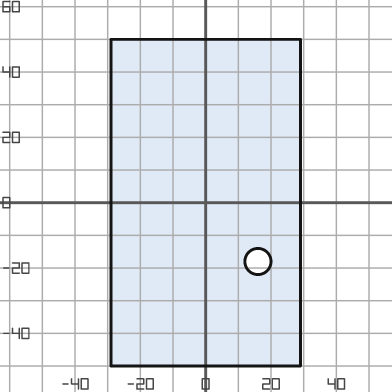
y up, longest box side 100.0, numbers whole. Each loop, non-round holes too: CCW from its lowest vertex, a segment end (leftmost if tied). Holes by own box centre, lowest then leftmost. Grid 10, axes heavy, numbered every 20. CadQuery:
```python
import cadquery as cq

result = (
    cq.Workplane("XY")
    .moveTo(-29.0, -50.0)
    .lineTo(29.0, -50.0)
    .lineTo(29.0, 50.0)
    .lineTo(-29.0, 50.0)
    .close()
    .moveTo(16.0, -18.0)
    .circle(4.0)
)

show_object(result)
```